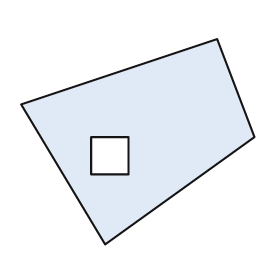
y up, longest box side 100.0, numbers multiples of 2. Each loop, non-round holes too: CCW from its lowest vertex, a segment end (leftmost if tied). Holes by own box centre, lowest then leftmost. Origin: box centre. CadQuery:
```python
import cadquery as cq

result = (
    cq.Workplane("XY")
    .moveTo(-14.0, -44.0)
    .lineTo(50.0, 2.0)
    .lineTo(34.0, 44.0)
    .lineTo(-50.0, 16.0)
    .close()
    .moveTo(-20.0, -14.0)
    .lineTo(-4.0, -14.0)
    .lineTo(-4.0, 2.0)
    .lineTo(-20.0, 2.0)
    .close()
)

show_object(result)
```